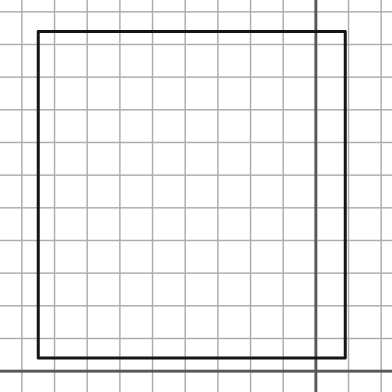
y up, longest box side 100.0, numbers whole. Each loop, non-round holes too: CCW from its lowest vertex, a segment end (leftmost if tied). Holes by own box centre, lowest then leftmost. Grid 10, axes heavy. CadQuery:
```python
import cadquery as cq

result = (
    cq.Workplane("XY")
    .moveTo(-85.0, 4.0)
    .lineTo(9.0, 4.0)
    .lineTo(9.0, 104.0)
    .lineTo(-85.0, 104.0)
    .close()
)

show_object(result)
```